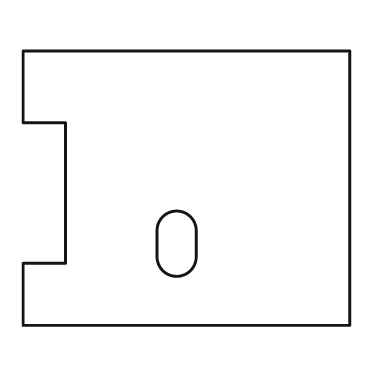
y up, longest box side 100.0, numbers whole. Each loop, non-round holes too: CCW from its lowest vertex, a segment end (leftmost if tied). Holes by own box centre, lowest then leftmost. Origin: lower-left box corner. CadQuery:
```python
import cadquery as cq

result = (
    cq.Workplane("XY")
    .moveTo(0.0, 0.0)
    .lineTo(100.0, 0.0)
    .lineTo(100.0, 84.0)
    .lineTo(0.0, 84.0)
    .lineTo(0.0, 62.0)
    .lineTo(13.0, 62.0)
    .lineTo(13.0, 19.0)
    .lineTo(0.0, 19.0)
    .close()
    .moveTo(41.0, 21.0)
    .threePointArc((47.0, 15.0), (53.0, 21.0))
    .lineTo(53.0, 29.0)
    .threePointArc((47.0, 35.0), (41.0, 29.0))
    .close()
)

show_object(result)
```